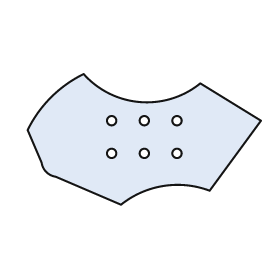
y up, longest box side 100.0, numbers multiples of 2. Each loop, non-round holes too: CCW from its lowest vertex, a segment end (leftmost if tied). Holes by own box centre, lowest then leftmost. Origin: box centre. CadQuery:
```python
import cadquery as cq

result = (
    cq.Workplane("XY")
    .moveTo(-10.0, -28.0)
    .threePointArc((8.0, -20.0), (28.0, -22.0))
    .lineTo(50.0, 8.0)
    .lineTo(24.0, 24.0)
    .threePointArc((-2.0, 16.0), (-26.0, 28.0))
    .threePointArc((-40.0, 18.0), (-50.0, 4.0))
    .lineTo(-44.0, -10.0)
    .threePointArc((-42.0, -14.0), (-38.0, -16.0))
    .close()
    .moveTo(-14.0, -6.0)
    .circle(2.0)
    .moveTo(0.0, -6.0)
    .circle(2.0)
    .moveTo(14.0, -6.0)
    .circle(2.0)
    .moveTo(-14.0, 8.0)
    .circle(2.0)
    .moveTo(0.0, 8.0)
    .circle(2.0)
    .moveTo(14.0, 8.0)
    .circle(2.0)
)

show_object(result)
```